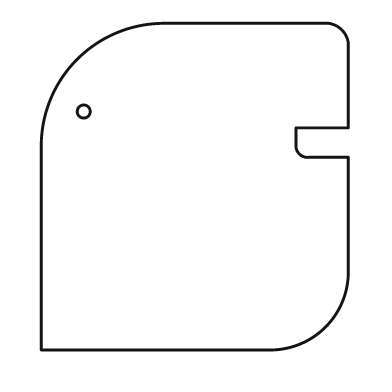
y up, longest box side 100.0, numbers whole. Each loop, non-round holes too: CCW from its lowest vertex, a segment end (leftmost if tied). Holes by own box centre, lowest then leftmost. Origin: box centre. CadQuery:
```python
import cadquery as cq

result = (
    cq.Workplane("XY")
    .moveTo(-47.0, -50.0)
    .lineTo(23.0, -50.0)
    .threePointArc((40.0, -43.0), (47.0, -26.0))
    .lineTo(47.0, 9.0)
    .lineTo(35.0, 9.0)
    .threePointArc((32.0, 10.0), (31.0, 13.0))
    .lineTo(31.0, 18.0)
    .lineTo(47.0, 18.0)
    .lineTo(47.0, 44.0)
    .threePointArc((45.0, 48.0), (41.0, 50.0))
    .lineTo(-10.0, 50.0)
    .threePointArc((-36.0, 39.0), (-47.0, 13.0))
    .close()
    .moveTo(-34.0, 23.0)
    .circle(2.0)
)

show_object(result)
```